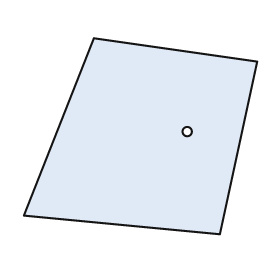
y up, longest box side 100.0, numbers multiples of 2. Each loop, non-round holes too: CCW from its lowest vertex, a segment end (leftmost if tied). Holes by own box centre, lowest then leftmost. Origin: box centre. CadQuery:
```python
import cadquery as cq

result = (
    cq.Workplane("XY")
    .moveTo(34.0, -42.0)
    .lineTo(50.0, 32.0)
    .lineTo(-20.0, 42.0)
    .lineTo(-50.0, -34.0)
    .close()
    .moveTo(20.0, 2.0)
    .circle(2.0)
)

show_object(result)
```